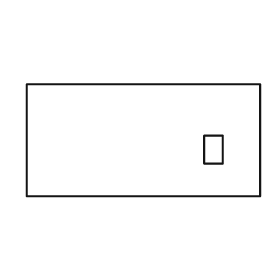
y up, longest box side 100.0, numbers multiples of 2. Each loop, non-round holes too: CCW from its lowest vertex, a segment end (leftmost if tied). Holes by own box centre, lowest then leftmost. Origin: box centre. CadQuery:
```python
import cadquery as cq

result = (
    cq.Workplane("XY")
    .moveTo(-50.0, -24.0)
    .lineTo(50.0, -24.0)
    .lineTo(50.0, 24.0)
    .lineTo(-50.0, 24.0)
    .close()
    .moveTo(26.0, -10.0)
    .lineTo(34.0, -10.0)
    .lineTo(34.0, 2.0)
    .lineTo(26.0, 2.0)
    .close()
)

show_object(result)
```